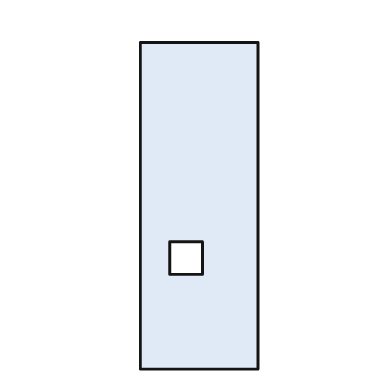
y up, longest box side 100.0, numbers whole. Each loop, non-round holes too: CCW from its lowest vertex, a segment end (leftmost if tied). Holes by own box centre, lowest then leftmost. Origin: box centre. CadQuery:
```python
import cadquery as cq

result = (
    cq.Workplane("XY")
    .moveTo(-18.0, -50.0)
    .lineTo(18.0, -50.0)
    .lineTo(18.0, 50.0)
    .lineTo(-18.0, 50.0)
    .close()
    .moveTo(-9.0, -21.0)
    .lineTo(1.0, -21.0)
    .lineTo(1.0, -11.0)
    .lineTo(-9.0, -11.0)
    .close()
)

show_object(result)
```